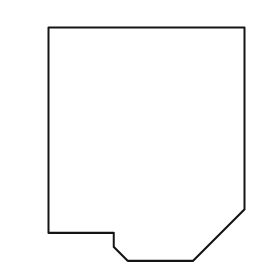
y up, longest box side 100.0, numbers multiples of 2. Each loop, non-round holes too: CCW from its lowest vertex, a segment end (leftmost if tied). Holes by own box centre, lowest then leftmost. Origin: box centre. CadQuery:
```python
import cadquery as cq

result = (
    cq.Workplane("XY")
    .moveTo(-8.0, -50.0)
    .lineTo(20.0, -50.0)
    .lineTo(42.0, -28.0)
    .lineTo(42.0, 50.0)
    .lineTo(-42.0, 50.0)
    .lineTo(-42.0, -38.0)
    .lineTo(-14.0, -38.0)
    .lineTo(-14.0, -44.0)
    .close()
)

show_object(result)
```